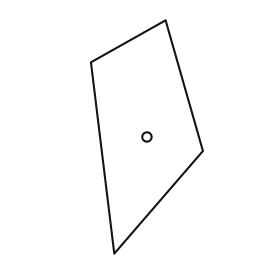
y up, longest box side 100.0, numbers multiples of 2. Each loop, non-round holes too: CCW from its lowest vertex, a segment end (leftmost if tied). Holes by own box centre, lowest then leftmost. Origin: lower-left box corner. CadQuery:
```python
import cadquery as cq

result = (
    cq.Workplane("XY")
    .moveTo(10.0, 0.0)
    .lineTo(48.0, 44.0)
    .lineTo(32.0, 100.0)
    .lineTo(0.0, 82.0)
    .close()
    .moveTo(24.0, 50.0)
    .circle(2.0)
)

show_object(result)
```